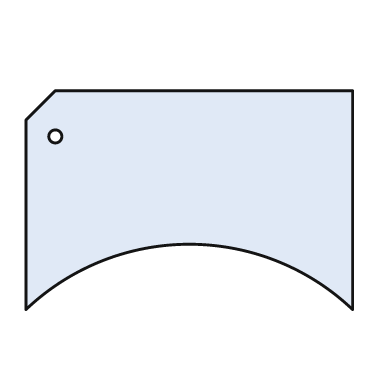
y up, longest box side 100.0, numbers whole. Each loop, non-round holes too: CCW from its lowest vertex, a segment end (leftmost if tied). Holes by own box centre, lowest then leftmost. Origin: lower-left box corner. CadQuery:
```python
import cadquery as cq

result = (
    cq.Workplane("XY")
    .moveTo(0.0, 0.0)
    .threePointArc((50.0, 20.0), (100.0, 0.0))
    .lineTo(100.0, 67.0)
    .lineTo(9.0, 67.0)
    .lineTo(0.0, 58.0)
    .close()
    .moveTo(9.0, 53.0)
    .circle(2.0)
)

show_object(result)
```